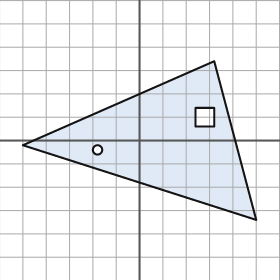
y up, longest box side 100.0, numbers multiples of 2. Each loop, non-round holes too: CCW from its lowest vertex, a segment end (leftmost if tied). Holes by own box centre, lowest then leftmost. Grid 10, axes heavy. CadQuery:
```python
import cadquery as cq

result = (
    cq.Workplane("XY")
    .moveTo(50.0, -34.0)
    .lineTo(32.0, 34.0)
    .lineTo(-50.0, -2.0)
    .close()
    .moveTo(-18.0, -4.0)
    .circle(2.0)
    .moveTo(24.0, 6.0)
    .lineTo(32.0, 6.0)
    .lineTo(32.0, 14.0)
    .lineTo(24.0, 14.0)
    .close()
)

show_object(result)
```